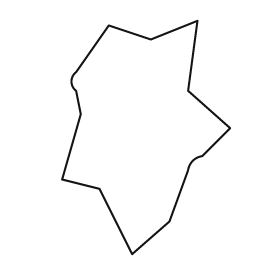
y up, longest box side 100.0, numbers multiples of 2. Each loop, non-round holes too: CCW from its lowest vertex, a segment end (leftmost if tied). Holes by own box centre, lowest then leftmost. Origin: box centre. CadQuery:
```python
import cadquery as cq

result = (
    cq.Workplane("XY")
    .moveTo(-6.0, -50.0)
    .lineTo(10.0, -36.0)
    .lineTo(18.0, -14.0)
    .threePointArc((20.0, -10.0), (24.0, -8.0))
    .lineTo(36.0, 4.0)
    .lineTo(18.0, 20.0)
    .lineTo(22.0, 50.0)
    .lineTo(2.0, 42.0)
    .lineTo(-16.0, 48.0)
    .lineTo(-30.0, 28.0)
    .threePointArc((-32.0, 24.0), (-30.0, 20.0))
    .lineTo(-28.0, 10.0)
    .lineTo(-36.0, -18.0)
    .lineTo(-20.0, -22.0)
    .close()
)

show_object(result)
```